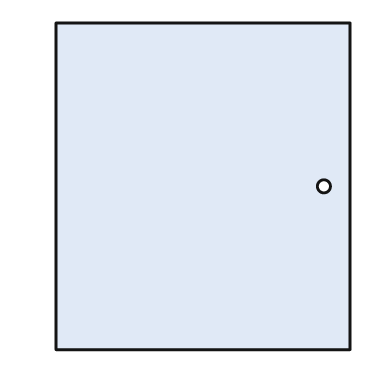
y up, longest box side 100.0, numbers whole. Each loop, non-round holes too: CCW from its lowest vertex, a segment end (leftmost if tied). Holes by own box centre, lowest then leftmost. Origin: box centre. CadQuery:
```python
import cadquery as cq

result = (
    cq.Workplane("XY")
    .moveTo(-45.0, -50.0)
    .lineTo(45.0, -50.0)
    .lineTo(45.0, 50.0)
    .lineTo(-45.0, 50.0)
    .close()
    .moveTo(37.0, 0.0)
    .circle(2.0)
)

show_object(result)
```